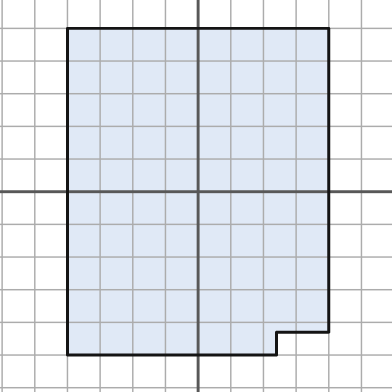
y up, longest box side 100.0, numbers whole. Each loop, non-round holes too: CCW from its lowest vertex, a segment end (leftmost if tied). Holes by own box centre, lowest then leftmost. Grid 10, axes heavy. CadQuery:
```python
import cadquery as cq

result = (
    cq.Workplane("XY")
    .moveTo(-40.0, -50.0)
    .lineTo(24.0, -50.0)
    .lineTo(24.0, -43.0)
    .lineTo(40.0, -43.0)
    .lineTo(40.0, 50.0)
    .lineTo(-40.0, 50.0)
    .close()
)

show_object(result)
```